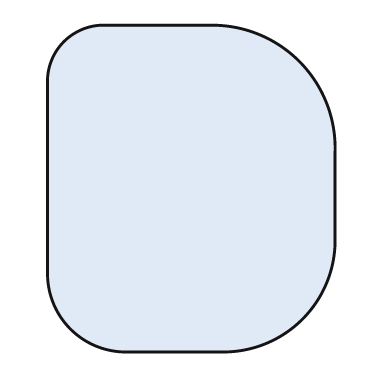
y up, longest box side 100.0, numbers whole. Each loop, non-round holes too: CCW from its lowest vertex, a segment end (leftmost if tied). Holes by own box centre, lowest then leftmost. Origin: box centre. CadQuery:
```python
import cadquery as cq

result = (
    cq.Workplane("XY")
    .moveTo(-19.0, -50.0)
    .lineTo(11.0, -50.0)
    .threePointArc((34.0, -40.0), (44.0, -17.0))
    .lineTo(44.0, 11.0)
    .threePointArc((33.0, 39.0), (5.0, 50.0))
    .lineTo(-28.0, 50.0)
    .threePointArc((-39.0, 45.0), (-44.0, 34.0))
    .lineTo(-44.0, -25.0)
    .threePointArc((-37.0, -43.0), (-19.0, -50.0))
    .close()
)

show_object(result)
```